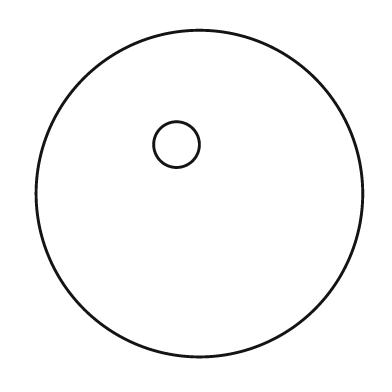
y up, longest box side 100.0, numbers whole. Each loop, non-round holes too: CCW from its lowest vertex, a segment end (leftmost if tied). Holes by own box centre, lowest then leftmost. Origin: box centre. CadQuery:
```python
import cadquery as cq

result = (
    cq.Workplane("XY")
    .moveTo(0.0, 0.0)
    .circle(50.0)
    .moveTo(-7.0, 15.0)
    .circle(7.0)
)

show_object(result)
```